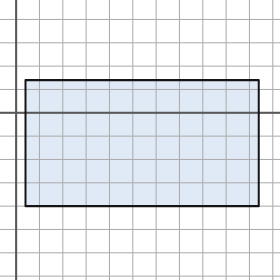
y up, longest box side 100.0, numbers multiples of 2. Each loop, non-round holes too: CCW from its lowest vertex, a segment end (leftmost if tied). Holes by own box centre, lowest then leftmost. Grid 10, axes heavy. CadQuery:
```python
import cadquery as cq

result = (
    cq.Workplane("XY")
    .moveTo(4.0, -40.0)
    .lineTo(104.0, -40.0)
    .lineTo(104.0, 14.0)
    .lineTo(4.0, 14.0)
    .close()
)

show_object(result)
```